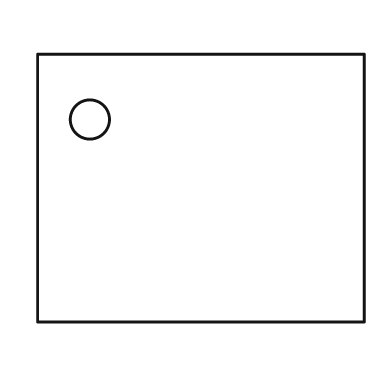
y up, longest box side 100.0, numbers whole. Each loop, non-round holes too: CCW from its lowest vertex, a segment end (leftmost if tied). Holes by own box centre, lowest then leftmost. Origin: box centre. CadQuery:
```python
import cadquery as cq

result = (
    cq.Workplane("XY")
    .moveTo(-50.0, -41.0)
    .lineTo(50.0, -41.0)
    .lineTo(50.0, 41.0)
    .lineTo(-50.0, 41.0)
    .close()
    .moveTo(-34.0, 21.0)
    .circle(6.0)
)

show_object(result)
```